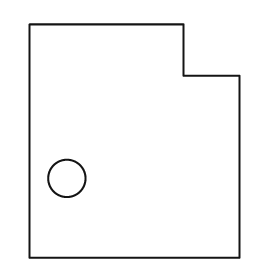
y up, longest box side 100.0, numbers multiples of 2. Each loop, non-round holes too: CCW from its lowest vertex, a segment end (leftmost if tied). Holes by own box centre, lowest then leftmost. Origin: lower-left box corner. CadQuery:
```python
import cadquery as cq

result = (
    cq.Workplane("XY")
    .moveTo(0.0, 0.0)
    .lineTo(90.0, 0.0)
    .lineTo(90.0, 78.0)
    .lineTo(66.0, 78.0)
    .lineTo(66.0, 100.0)
    .lineTo(0.0, 100.0)
    .close()
    .moveTo(16.0, 34.0)
    .circle(8.0)
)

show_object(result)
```